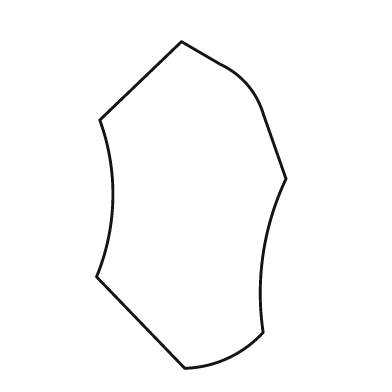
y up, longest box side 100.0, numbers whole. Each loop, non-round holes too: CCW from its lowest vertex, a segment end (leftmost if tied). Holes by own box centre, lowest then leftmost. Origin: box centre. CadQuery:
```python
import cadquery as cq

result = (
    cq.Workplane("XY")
    .moveTo(-2.0, -50.0)
    .threePointArc((11.0, -47.0), (22.0, -39.0))
    .threePointArc((22.0, -15.0), (29.0, 8.0))
    .lineTo(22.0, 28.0)
    .threePointArc((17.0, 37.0), (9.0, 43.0))
    .lineTo(-3.0, 50.0)
    .lineTo(-28.0, 26.0)
    .threePointArc((-24.0, 2.0), (-29.0, -22.0))
    .close()
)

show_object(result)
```